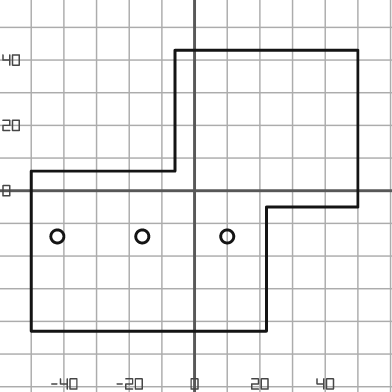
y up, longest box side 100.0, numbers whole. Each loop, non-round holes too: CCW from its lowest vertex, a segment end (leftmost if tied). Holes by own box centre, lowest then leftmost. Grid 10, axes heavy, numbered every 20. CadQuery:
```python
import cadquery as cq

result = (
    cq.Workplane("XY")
    .moveTo(-50.0, -43.0)
    .lineTo(22.0, -43.0)
    .lineTo(22.0, -5.0)
    .lineTo(50.0, -5.0)
    .lineTo(50.0, 43.0)
    .lineTo(-6.0, 43.0)
    .lineTo(-6.0, 6.0)
    .lineTo(-50.0, 6.0)
    .close()
    .moveTo(-42.0, -14.0)
    .circle(2.0)
    .moveTo(-16.0, -14.0)
    .circle(2.0)
    .moveTo(10.0, -14.0)
    .circle(2.0)
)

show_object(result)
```